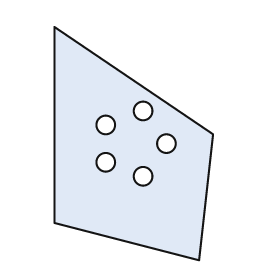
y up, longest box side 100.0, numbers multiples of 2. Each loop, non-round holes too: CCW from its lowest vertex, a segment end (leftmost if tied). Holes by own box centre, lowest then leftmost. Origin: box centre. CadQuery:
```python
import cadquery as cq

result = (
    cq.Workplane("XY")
    .moveTo(28.0, -50.0)
    .lineTo(34.0, 4.0)
    .lineTo(-34.0, 50.0)
    .lineTo(-34.0, -34.0)
    .close()
    .moveTo(4.0, -14.0)
    .circle(4.0)
    .moveTo(-12.0, -8.0)
    .circle(4.0)
    .moveTo(14.0, 0.0)
    .circle(4.0)
    .moveTo(-12.0, 8.0)
    .circle(4.0)
    .moveTo(4.0, 14.0)
    .circle(4.0)
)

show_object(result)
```